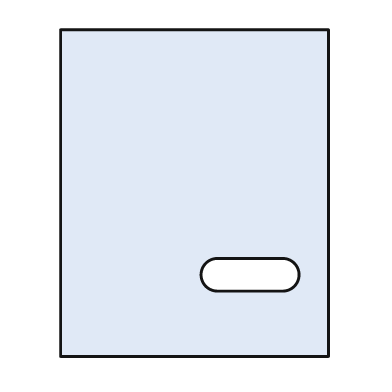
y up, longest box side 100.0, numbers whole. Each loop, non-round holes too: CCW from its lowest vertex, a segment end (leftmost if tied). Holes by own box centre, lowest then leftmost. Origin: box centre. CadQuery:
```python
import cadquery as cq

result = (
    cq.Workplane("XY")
    .moveTo(-41.0, -50.0)
    .lineTo(41.0, -50.0)
    .lineTo(41.0, 50.0)
    .lineTo(-41.0, 50.0)
    .close()
    .moveTo(7.0, -30.0)
    .lineTo(27.0, -30.0)
    .threePointArc((32.0, -25.0), (27.0, -20.0))
    .lineTo(7.0, -20.0)
    .threePointArc((2.0, -25.0), (7.0, -30.0))
    .close()
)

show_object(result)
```